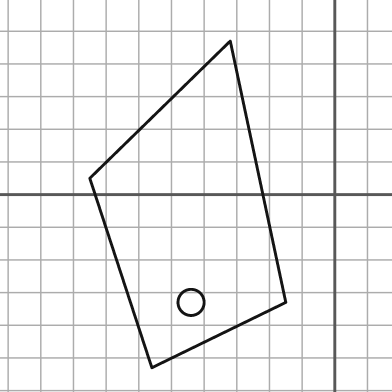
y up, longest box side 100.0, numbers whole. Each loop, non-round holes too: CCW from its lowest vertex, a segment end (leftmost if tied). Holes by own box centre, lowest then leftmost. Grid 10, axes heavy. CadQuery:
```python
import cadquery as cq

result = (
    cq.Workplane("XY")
    .moveTo(-56.0, -53.0)
    .lineTo(-15.0, -33.0)
    .lineTo(-32.0, 47.0)
    .lineTo(-75.0, 5.0)
    .close()
    .moveTo(-44.0, -33.0)
    .circle(4.0)
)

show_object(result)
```